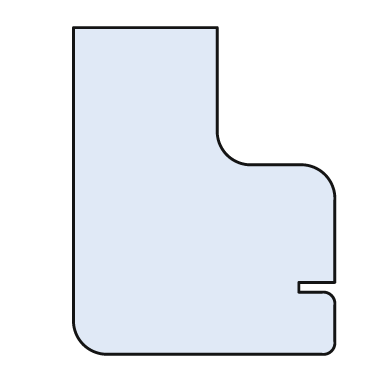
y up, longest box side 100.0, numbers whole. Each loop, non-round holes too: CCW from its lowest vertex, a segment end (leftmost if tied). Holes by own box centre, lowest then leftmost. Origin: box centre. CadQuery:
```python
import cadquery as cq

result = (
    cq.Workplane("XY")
    .moveTo(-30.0, -50.0)
    .lineTo(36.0, -50.0)
    .threePointArc((39.0, -49.0), (40.0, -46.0))
    .lineTo(40.0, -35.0)
    .threePointArc((39.0, -32.0), (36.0, -31.0))
    .lineTo(29.0, -31.0)
    .lineTo(29.0, -28.0)
    .lineTo(40.0, -28.0)
    .lineTo(40.0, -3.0)
    .threePointArc((37.0, 5.0), (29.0, 8.0))
    .lineTo(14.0, 8.0)
    .threePointArc((7.0, 11.0), (4.0, 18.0))
    .lineTo(4.0, 50.0)
    .lineTo(-40.0, 50.0)
    .lineTo(-40.0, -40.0)
    .threePointArc((-37.0, -47.0), (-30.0, -50.0))
    .close()
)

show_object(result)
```